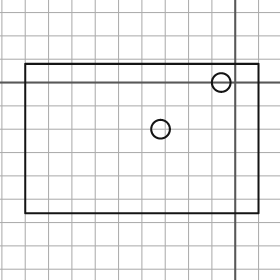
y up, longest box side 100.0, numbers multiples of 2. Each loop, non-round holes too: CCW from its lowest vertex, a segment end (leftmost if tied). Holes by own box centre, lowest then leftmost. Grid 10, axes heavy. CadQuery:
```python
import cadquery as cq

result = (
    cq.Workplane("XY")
    .moveTo(-90.0, -56.0)
    .lineTo(10.0, -56.0)
    .lineTo(10.0, 8.0)
    .lineTo(-90.0, 8.0)
    .close()
    .moveTo(-32.0, -20.0)
    .circle(4.0)
    .moveTo(-6.0, 0.0)
    .circle(4.0)
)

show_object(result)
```